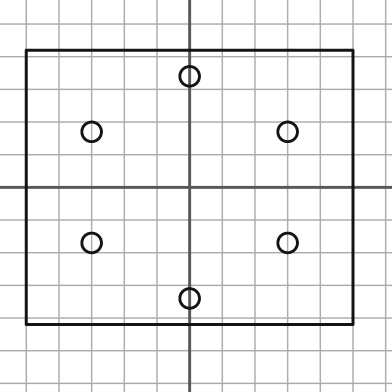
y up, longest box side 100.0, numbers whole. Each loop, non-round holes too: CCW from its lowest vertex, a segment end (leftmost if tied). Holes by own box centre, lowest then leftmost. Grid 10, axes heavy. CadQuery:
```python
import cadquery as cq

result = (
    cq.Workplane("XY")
    .moveTo(-50.0, -42.0)
    .lineTo(50.0, -42.0)
    .lineTo(50.0, 42.0)
    .lineTo(-50.0, 42.0)
    .close()
    .moveTo(0.0, -34.0)
    .circle(3.0)
    .moveTo(-30.0, -17.0)
    .circle(3.0)
    .moveTo(30.0, -17.0)
    .circle(3.0)
    .moveTo(-30.0, 17.0)
    .circle(3.0)
    .moveTo(30.0, 17.0)
    .circle(3.0)
    .moveTo(0.0, 34.0)
    .circle(3.0)
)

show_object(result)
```